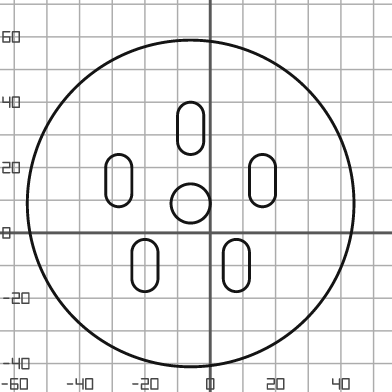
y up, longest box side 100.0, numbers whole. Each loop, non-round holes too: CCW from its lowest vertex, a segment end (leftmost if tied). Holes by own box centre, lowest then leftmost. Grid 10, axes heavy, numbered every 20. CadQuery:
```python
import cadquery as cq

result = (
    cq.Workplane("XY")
    .moveTo(-6.0, 9.0)
    .circle(50.0)
    .moveTo(-24.0, -14.0)
    .threePointArc((-20.0, -18.0), (-16.0, -14.0))
    .lineTo(-16.0, -6.0)
    .threePointArc((-20.0, -2.0), (-24.0, -6.0))
    .close()
    .moveTo(4.0, -14.0)
    .threePointArc((8.0, -18.0), (12.0, -14.0))
    .lineTo(12.0, -6.0)
    .threePointArc((8.0, -2.0), (4.0, -6.0))
    .close()
    .moveTo(-6.0, 9.0)
    .circle(6.0)
    .moveTo(-32.0, 12.0)
    .threePointArc((-28.0, 8.0), (-24.0, 12.0))
    .lineTo(-24.0, 20.0)
    .threePointArc((-28.0, 24.0), (-32.0, 20.0))
    .close()
    .moveTo(12.0, 12.0)
    .threePointArc((16.0, 8.0), (20.0, 12.0))
    .lineTo(20.0, 20.0)
    .threePointArc((16.0, 24.0), (12.0, 20.0))
    .close()
    .moveTo(-10.0, 28.0)
    .threePointArc((-6.0, 24.0), (-2.0, 28.0))
    .lineTo(-2.0, 36.0)
    .threePointArc((-6.0, 40.0), (-10.0, 36.0))
    .close()
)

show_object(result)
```